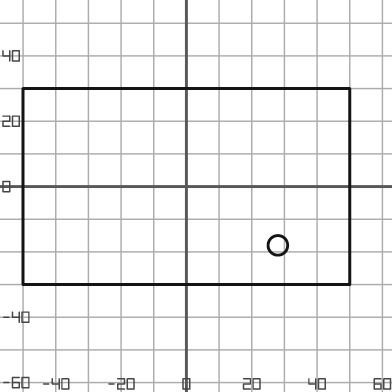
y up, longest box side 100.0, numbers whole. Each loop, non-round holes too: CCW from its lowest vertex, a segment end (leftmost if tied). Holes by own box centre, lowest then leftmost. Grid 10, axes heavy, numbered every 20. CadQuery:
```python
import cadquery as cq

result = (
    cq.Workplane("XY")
    .moveTo(-50.0, -30.0)
    .lineTo(50.0, -30.0)
    .lineTo(50.0, 30.0)
    .lineTo(-50.0, 30.0)
    .close()
    .moveTo(28.0, -18.0)
    .circle(3.0)
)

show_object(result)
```